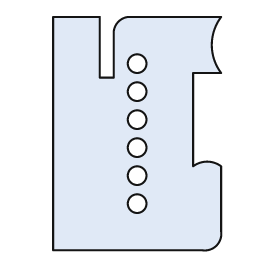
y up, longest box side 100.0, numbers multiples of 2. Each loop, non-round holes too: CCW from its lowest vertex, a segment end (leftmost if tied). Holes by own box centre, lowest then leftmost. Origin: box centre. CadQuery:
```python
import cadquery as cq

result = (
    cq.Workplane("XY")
    .moveTo(-36.0, -50.0)
    .lineTo(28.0, -50.0)
    .threePointArc((34.0, -48.0), (36.0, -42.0))
    .lineTo(36.0, -14.0)
    .threePointArc((30.0, -12.0), (24.0, -14.0))
    .lineTo(24.0, 26.0)
    .lineTo(36.0, 26.0)
    .threePointArc((32.0, 38.0), (36.0, 50.0))
    .lineTo(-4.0, 50.0)
    .threePointArc((-8.0, 48.0), (-10.0, 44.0))
    .lineTo(-10.0, 24.0)
    .lineTo(-16.0, 24.0)
    .lineTo(-16.0, 50.0)
    .lineTo(-36.0, 50.0)
    .close()
    .moveTo(0.0, -30.0)
    .circle(4.0)
    .moveTo(0.0, -18.0)
    .circle(4.0)
    .moveTo(0.0, -6.0)
    .circle(4.0)
    .moveTo(0.0, 6.0)
    .circle(4.0)
    .moveTo(0.0, 18.0)
    .circle(4.0)
    .moveTo(0.0, 30.0)
    .circle(4.0)
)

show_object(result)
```